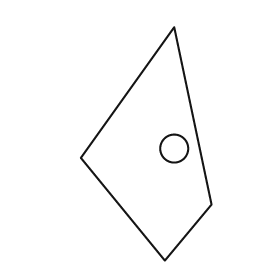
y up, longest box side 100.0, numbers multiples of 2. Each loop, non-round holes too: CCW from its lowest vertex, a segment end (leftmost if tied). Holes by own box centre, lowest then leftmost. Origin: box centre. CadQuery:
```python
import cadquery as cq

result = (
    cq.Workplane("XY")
    .moveTo(8.0, -50.0)
    .lineTo(28.0, -26.0)
    .lineTo(12.0, 50.0)
    .lineTo(-28.0, -6.0)
    .close()
    .moveTo(12.0, -2.0)
    .circle(6.0)
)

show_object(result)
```